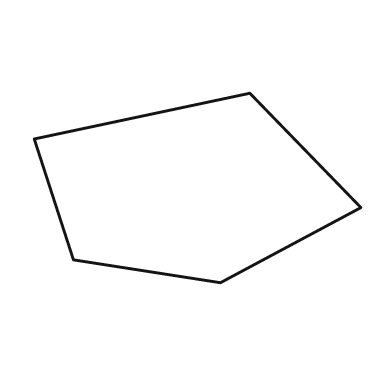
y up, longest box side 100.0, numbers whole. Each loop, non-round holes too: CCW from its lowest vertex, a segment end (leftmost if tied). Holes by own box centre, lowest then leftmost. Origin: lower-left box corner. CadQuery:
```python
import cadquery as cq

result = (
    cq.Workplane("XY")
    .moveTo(57.0, 0.0)
    .lineTo(100.0, 23.0)
    .lineTo(66.0, 58.0)
    .lineTo(0.0, 44.0)
    .lineTo(12.0, 7.0)
    .close()
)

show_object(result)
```